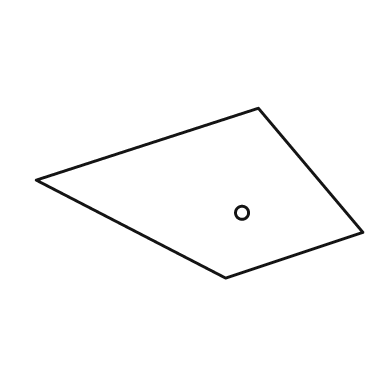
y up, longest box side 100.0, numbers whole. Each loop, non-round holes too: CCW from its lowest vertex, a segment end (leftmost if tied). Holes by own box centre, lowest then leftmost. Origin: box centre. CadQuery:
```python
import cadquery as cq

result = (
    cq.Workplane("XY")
    .moveTo(8.0, -26.0)
    .lineTo(50.0, -12.0)
    .lineTo(18.0, 26.0)
    .lineTo(-50.0, 4.0)
    .close()
    .moveTo(13.0, -6.0)
    .circle(2.0)
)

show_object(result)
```